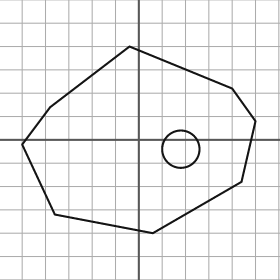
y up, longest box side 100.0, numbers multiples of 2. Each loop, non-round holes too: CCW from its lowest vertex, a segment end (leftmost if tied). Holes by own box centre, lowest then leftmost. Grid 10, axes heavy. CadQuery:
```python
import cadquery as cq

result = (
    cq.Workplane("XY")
    .moveTo(6.0, -40.0)
    .lineTo(44.0, -18.0)
    .lineTo(50.0, 8.0)
    .lineTo(40.0, 22.0)
    .lineTo(-4.0, 40.0)
    .lineTo(-38.0, 14.0)
    .lineTo(-50.0, -2.0)
    .lineTo(-36.0, -32.0)
    .close()
    .moveTo(18.0, -4.0)
    .circle(8.0)
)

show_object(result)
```